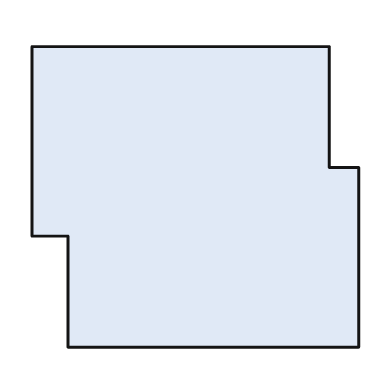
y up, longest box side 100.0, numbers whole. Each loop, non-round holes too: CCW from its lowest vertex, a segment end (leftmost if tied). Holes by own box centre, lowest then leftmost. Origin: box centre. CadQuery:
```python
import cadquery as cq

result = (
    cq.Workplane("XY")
    .moveTo(-39.0, -46.0)
    .lineTo(50.0, -46.0)
    .lineTo(50.0, 9.0)
    .lineTo(41.0, 9.0)
    .lineTo(41.0, 46.0)
    .lineTo(-50.0, 46.0)
    .lineTo(-50.0, -12.0)
    .lineTo(-39.0, -12.0)
    .close()
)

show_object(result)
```